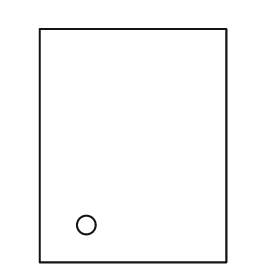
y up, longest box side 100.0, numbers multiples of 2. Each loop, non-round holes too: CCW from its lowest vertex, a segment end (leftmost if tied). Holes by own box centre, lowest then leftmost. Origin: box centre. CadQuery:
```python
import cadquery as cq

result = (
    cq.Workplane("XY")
    .moveTo(-40.0, -50.0)
    .lineTo(40.0, -50.0)
    .lineTo(40.0, 50.0)
    .lineTo(-40.0, 50.0)
    .close()
    .moveTo(-20.0, -34.0)
    .circle(4.0)
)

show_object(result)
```